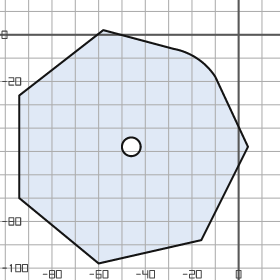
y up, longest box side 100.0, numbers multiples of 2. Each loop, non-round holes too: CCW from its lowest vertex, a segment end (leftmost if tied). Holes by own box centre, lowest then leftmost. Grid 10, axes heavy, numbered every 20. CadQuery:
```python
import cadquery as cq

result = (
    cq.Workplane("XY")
    .moveTo(-60.0, -98.0)
    .lineTo(-16.0, -88.0)
    .lineTo(4.0, -48.0)
    .lineTo(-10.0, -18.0)
    .threePointArc((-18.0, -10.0), (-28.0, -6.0))
    .lineTo(-58.0, 2.0)
    .lineTo(-94.0, -26.0)
    .lineTo(-94.0, -70.0)
    .close()
    .moveTo(-46.0, -48.0)
    .circle(4.0)
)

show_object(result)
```